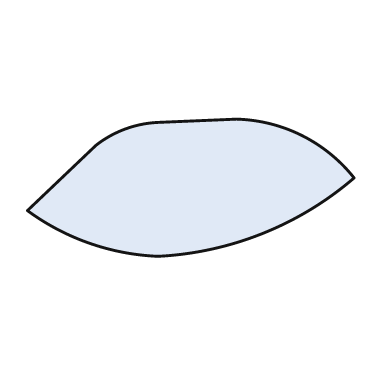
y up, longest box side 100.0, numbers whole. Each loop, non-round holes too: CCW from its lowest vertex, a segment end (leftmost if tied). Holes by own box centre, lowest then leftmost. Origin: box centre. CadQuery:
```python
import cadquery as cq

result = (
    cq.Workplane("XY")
    .moveTo(-10.0, -21.0)
    .threePointArc((22.0, -14.0), (50.0, 3.0))
    .threePointArc((34.0, 16.0), (14.0, 21.0))
    .lineTo(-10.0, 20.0)
    .threePointArc((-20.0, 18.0), (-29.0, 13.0))
    .lineTo(-50.0, -7.0)
    .threePointArc((-31.0, -17.0), (-10.0, -21.0))
    .close()
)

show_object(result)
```